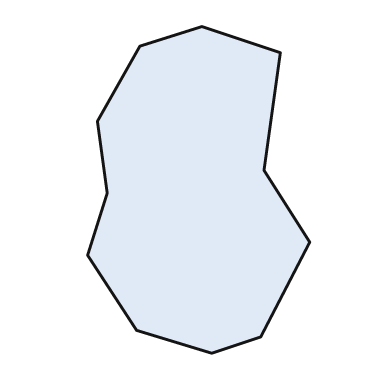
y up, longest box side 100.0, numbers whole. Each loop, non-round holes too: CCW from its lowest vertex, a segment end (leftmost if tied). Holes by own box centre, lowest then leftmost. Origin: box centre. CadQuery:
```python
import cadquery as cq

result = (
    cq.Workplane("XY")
    .moveTo(4.0, -50.0)
    .lineTo(19.0, -45.0)
    .lineTo(34.0, -16.0)
    .lineTo(20.0, 6.0)
    .lineTo(25.0, 42.0)
    .lineTo(1.0, 50.0)
    .lineTo(-18.0, 44.0)
    .lineTo(-31.0, 21.0)
    .lineTo(-28.0, -1.0)
    .lineTo(-34.0, -20.0)
    .lineTo(-19.0, -43.0)
    .close()
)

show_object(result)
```